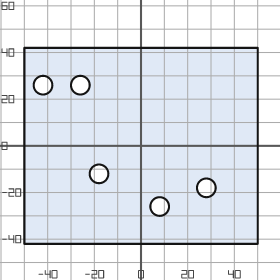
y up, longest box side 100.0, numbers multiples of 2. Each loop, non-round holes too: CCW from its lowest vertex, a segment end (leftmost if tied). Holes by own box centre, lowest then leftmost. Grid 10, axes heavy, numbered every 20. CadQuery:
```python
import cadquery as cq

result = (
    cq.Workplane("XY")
    .moveTo(-50.0, -42.0)
    .lineTo(50.0, -42.0)
    .lineTo(50.0, 42.0)
    .lineTo(-50.0, 42.0)
    .close()
    .moveTo(8.0, -26.0)
    .circle(4.0)
    .moveTo(28.0, -18.0)
    .circle(4.0)
    .moveTo(-18.0, -12.0)
    .circle(4.0)
    .moveTo(-42.0, 26.0)
    .circle(4.0)
    .moveTo(-26.0, 26.0)
    .circle(4.0)
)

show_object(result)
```